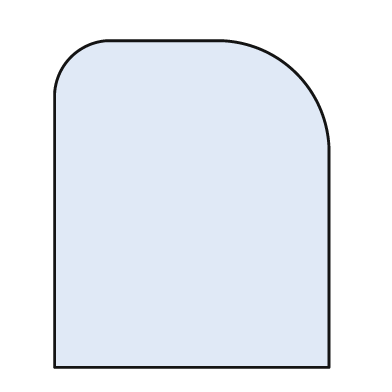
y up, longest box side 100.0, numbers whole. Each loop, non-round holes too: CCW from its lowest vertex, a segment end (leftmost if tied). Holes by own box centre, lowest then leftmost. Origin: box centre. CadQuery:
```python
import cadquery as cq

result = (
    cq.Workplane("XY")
    .moveTo(-42.0, -50.0)
    .lineTo(42.0, -50.0)
    .lineTo(42.0, 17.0)
    .threePointArc((32.0, 40.0), (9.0, 50.0))
    .lineTo(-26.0, 50.0)
    .threePointArc((-37.0, 45.0), (-42.0, 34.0))
    .close()
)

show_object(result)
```